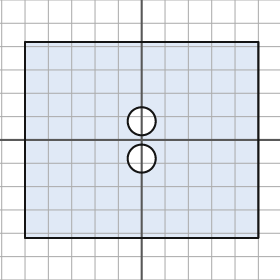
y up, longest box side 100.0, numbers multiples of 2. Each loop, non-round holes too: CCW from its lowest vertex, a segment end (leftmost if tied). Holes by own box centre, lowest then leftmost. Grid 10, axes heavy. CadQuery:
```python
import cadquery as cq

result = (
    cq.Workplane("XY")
    .moveTo(-50.0, -42.0)
    .lineTo(50.0, -42.0)
    .lineTo(50.0, 42.0)
    .lineTo(-50.0, 42.0)
    .close()
    .moveTo(0.0, -8.0)
    .circle(6.0)
    .moveTo(0.0, 8.0)
    .circle(6.0)
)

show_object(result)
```